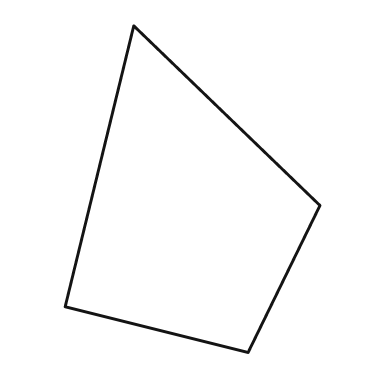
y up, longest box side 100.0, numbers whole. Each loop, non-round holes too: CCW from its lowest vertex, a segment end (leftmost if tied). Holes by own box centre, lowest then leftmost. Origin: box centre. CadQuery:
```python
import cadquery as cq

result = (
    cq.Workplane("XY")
    .moveTo(17.0, -50.0)
    .lineTo(39.0, -5.0)
    .lineTo(-18.0, 50.0)
    .lineTo(-39.0, -36.0)
    .close()
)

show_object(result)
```